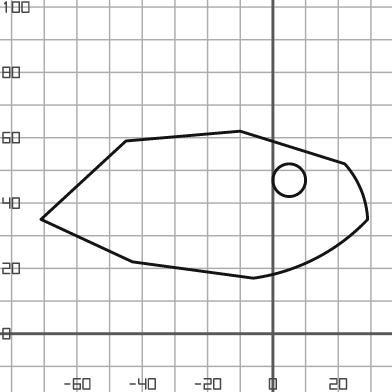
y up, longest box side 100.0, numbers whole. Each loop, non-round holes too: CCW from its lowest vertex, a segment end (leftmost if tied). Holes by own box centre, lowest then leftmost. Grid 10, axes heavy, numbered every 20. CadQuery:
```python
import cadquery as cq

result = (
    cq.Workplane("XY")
    .moveTo(-6.0, 17.0)
    .threePointArc((13.0, 23.0), (29.0, 35.0))
    .threePointArc((27.0, 44.0), (22.0, 52.0))
    .lineTo(-10.0, 62.0)
    .lineTo(-45.0, 59.0)
    .lineTo(-71.0, 35.0)
    .lineTo(-43.0, 22.0)
    .close()
    .moveTo(5.0, 47.0)
    .circle(5.0)
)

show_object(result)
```